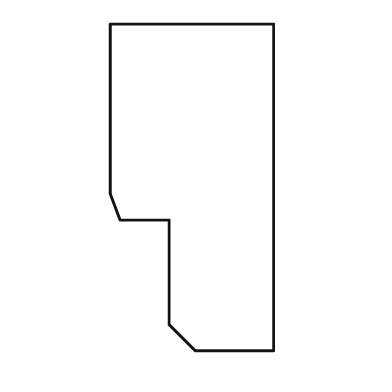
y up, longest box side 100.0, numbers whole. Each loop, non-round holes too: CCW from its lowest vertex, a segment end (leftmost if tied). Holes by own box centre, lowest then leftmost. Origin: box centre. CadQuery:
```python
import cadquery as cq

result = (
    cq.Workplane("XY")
    .moveTo(1.0, -50.0)
    .lineTo(25.0, -50.0)
    .lineTo(25.0, 50.0)
    .lineTo(-25.0, 50.0)
    .lineTo(-25.0, -2.0)
    .lineTo(-22.0, -10.0)
    .lineTo(-7.0, -10.0)
    .lineTo(-7.0, -42.0)
    .close()
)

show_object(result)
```